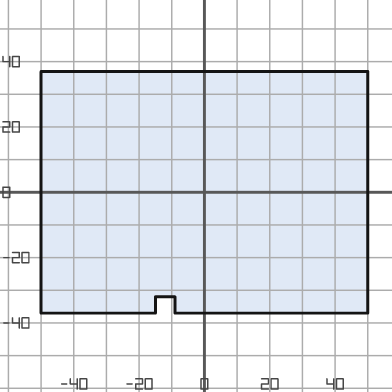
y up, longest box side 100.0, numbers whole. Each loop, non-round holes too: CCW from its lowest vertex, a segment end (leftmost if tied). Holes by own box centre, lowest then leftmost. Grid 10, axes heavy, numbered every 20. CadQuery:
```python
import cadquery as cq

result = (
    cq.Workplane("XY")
    .moveTo(-50.0, -37.0)
    .lineTo(-15.0, -37.0)
    .lineTo(-15.0, -32.0)
    .lineTo(-9.0, -32.0)
    .lineTo(-9.0, -37.0)
    .lineTo(50.0, -37.0)
    .lineTo(50.0, 37.0)
    .lineTo(-50.0, 37.0)
    .close()
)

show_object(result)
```